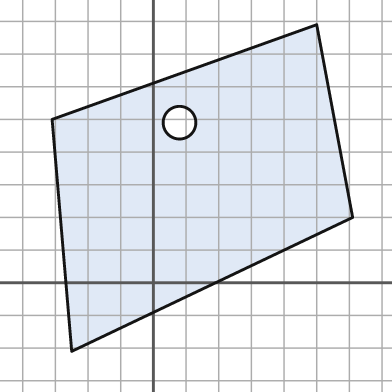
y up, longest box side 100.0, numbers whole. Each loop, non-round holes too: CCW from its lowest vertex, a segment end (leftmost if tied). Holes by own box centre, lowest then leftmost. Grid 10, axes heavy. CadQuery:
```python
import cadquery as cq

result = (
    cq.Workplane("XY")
    .moveTo(-25.0, -21.0)
    .lineTo(61.0, 20.0)
    .lineTo(50.0, 79.0)
    .lineTo(-31.0, 50.0)
    .close()
    .moveTo(8.0, 49.0)
    .circle(5.0)
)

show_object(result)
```